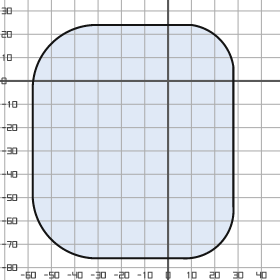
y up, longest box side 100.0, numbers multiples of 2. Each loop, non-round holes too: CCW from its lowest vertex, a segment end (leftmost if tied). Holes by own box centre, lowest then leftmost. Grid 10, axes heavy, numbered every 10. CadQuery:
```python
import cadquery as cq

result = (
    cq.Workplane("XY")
    .moveTo(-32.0, -76.0)
    .lineTo(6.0, -76.0)
    .threePointArc((22.0, -70.0), (28.0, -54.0))
    .lineTo(28.0, 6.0)
    .threePointArc((22.0, 18.0), (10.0, 24.0))
    .lineTo(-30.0, 24.0)
    .threePointArc((-50.0, 16.0), (-58.0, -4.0))
    .lineTo(-58.0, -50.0)
    .threePointArc((-50.0, -68.0), (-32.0, -76.0))
    .close()
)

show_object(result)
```